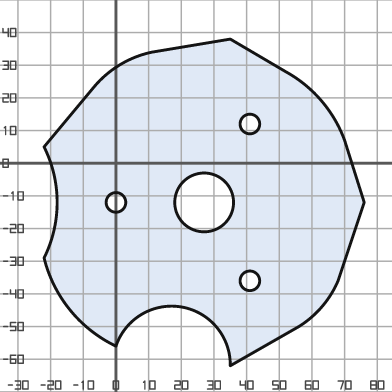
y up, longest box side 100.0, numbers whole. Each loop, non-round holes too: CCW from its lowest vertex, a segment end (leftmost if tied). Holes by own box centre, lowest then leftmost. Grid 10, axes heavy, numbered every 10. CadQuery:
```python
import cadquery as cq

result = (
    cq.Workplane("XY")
    .moveTo(35.0, -62.0)
    .lineTo(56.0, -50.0)
    .threePointArc((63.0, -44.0), (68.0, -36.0))
    .lineTo(76.0, -12.0)
    .lineTo(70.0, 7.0)
    .threePointArc((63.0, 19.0), (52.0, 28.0))
    .lineTo(35.0, 38.0)
    .lineTo(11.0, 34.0)
    .threePointArc((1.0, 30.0), (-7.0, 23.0))
    .lineTo(-22.0, 5.0)
    .threePointArc((-18.0, -12.0), (-22.0, -29.0))
    .threePointArc((-14.0, -45.0), (0.0, -56.0))
    .threePointArc((20.0, -44.0), (35.0, -62.0))
    .close()
    .moveTo(41.0, -36.0)
    .circle(3.0)
    .moveTo(0.0, -12.0)
    .circle(3.0)
    .moveTo(27.0, -12.0)
    .circle(9.0)
    .moveTo(41.0, 12.0)
    .circle(3.0)
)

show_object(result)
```